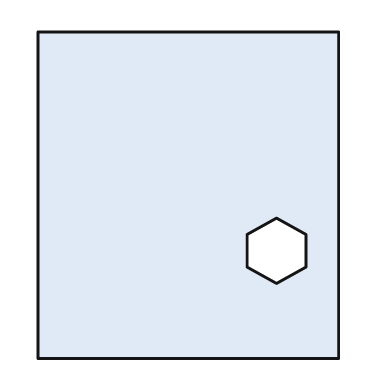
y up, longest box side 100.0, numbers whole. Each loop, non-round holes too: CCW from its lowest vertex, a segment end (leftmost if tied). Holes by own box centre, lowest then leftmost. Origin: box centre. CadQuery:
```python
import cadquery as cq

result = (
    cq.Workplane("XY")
    .moveTo(-46.0, -50.0)
    .lineTo(46.0, -50.0)
    .lineTo(46.0, 50.0)
    .lineTo(-46.0, 50.0)
    .close()
    .moveTo(27.0, -27.0)
    .lineTo(36.0, -22.0)
    .lineTo(36.0, -12.0)
    .lineTo(27.0, -7.0)
    .lineTo(18.0, -12.0)
    .lineTo(18.0, -22.0)
    .close()
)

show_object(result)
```